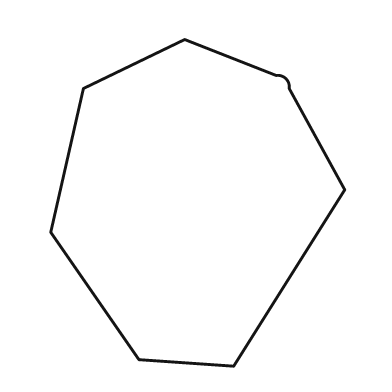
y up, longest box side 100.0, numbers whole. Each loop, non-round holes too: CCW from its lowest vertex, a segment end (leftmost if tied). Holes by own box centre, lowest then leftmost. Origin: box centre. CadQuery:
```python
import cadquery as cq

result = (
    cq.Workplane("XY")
    .moveTo(11.0, -50.0)
    .lineTo(45.0, 4.0)
    .lineTo(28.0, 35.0)
    .threePointArc((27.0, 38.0), (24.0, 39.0))
    .lineTo(-4.0, 50.0)
    .lineTo(-35.0, 35.0)
    .lineTo(-45.0, -9.0)
    .lineTo(-18.0, -48.0)
    .close()
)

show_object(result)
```